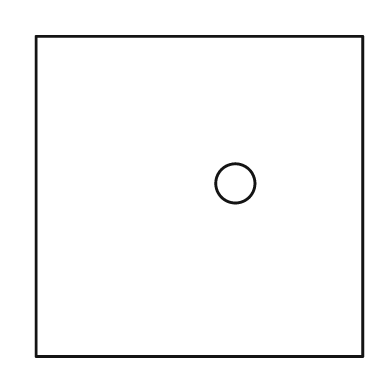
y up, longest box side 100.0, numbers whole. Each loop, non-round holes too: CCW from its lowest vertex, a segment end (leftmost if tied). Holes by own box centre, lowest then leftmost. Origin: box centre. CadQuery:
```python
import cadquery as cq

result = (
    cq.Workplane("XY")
    .moveTo(-50.0, -49.0)
    .lineTo(50.0, -49.0)
    .lineTo(50.0, 49.0)
    .lineTo(-50.0, 49.0)
    .close()
    .moveTo(11.0, 4.0)
    .circle(6.0)
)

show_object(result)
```